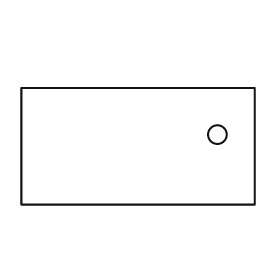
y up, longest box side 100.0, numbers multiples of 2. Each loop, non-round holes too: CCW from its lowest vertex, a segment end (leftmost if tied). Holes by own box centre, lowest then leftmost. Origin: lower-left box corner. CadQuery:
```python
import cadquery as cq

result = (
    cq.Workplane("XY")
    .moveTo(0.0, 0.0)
    .lineTo(100.0, 0.0)
    .lineTo(100.0, 50.0)
    .lineTo(0.0, 50.0)
    .close()
    .moveTo(84.0, 30.0)
    .circle(4.0)
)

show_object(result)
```